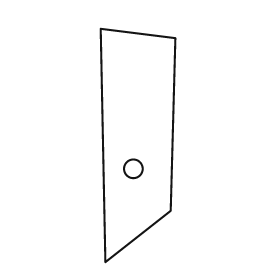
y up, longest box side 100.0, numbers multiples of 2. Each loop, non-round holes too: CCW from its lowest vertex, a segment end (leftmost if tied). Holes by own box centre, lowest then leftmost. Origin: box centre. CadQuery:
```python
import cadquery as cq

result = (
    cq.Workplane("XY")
    .moveTo(-14.0, -50.0)
    .lineTo(14.0, -28.0)
    .lineTo(16.0, 46.0)
    .lineTo(-16.0, 50.0)
    .close()
    .moveTo(-2.0, -10.0)
    .circle(4.0)
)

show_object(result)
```